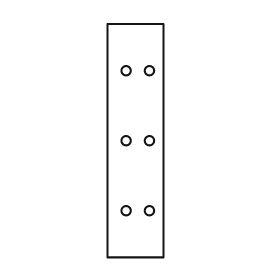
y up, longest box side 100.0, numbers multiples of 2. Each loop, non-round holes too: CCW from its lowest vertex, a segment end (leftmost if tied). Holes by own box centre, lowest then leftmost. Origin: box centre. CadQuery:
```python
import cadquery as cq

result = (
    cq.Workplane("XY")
    .moveTo(-12.0, -50.0)
    .lineTo(12.0, -50.0)
    .lineTo(12.0, 50.0)
    .lineTo(-12.0, 50.0)
    .close()
    .moveTo(-4.0, -30.0)
    .circle(2.0)
    .moveTo(6.0, -30.0)
    .circle(2.0)
    .moveTo(-4.0, 0.0)
    .circle(2.0)
    .moveTo(6.0, 0.0)
    .circle(2.0)
    .moveTo(-4.0, 30.0)
    .circle(2.0)
    .moveTo(6.0, 30.0)
    .circle(2.0)
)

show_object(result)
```